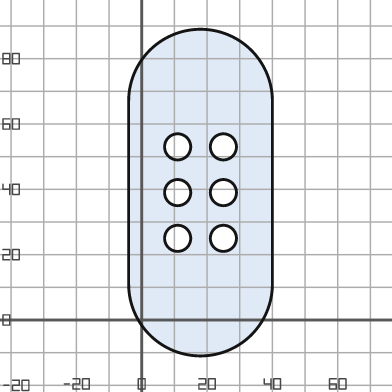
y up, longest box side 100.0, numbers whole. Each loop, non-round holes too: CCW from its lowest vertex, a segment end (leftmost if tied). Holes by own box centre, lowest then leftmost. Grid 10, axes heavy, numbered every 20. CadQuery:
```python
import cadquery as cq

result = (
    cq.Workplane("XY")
    .moveTo(-4.0, 11.0)
    .threePointArc((18.0, -11.0), (40.0, 11.0))
    .lineTo(40.0, 67.0)
    .threePointArc((18.0, 89.0), (-4.0, 67.0))
    .close()
    .moveTo(11.0, 25.0)
    .circle(4.0)
    .moveTo(25.0, 25.0)
    .circle(4.0)
    .moveTo(11.0, 39.0)
    .circle(4.0)
    .moveTo(25.0, 39.0)
    .circle(4.0)
    .moveTo(11.0, 53.0)
    .circle(4.0)
    .moveTo(25.0, 53.0)
    .circle(4.0)
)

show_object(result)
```